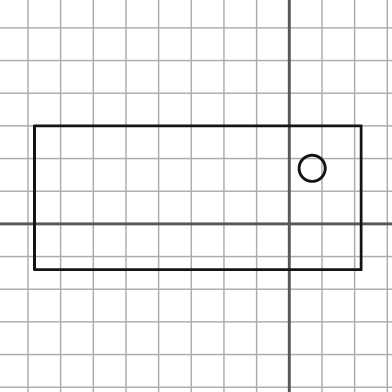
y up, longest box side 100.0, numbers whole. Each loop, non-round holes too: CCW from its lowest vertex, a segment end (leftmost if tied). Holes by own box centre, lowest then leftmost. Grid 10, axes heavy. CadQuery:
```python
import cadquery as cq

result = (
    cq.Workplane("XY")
    .moveTo(-78.0, -14.0)
    .lineTo(22.0, -14.0)
    .lineTo(22.0, 30.0)
    .lineTo(-78.0, 30.0)
    .close()
    .moveTo(7.0, 17.0)
    .circle(4.0)
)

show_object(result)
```